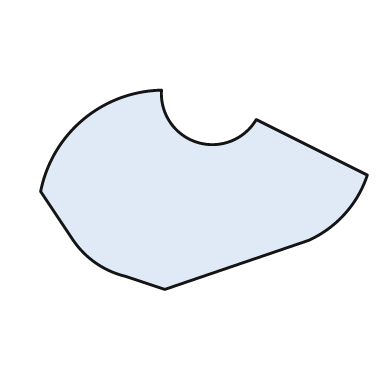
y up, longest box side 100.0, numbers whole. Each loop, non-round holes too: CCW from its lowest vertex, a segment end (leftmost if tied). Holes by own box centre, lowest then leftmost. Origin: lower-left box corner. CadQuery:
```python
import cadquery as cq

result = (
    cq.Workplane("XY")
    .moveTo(38.0, 0.0)
    .lineTo(82.0, 15.0)
    .threePointArc((93.0, 23.0), (100.0, 35.0))
    .lineTo(66.0, 52.0)
    .threePointArc((48.0, 45.0), (37.0, 61.0))
    .threePointArc((13.0, 52.0), (0.0, 30.0))
    .lineTo(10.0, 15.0)
    .threePointArc((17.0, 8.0), (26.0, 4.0))
    .close()
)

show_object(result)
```